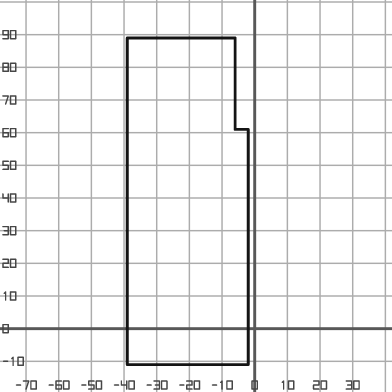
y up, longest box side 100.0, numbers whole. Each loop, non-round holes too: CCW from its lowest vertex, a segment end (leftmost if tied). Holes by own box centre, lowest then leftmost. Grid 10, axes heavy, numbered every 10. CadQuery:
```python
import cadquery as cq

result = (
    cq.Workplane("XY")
    .moveTo(-39.0, -11.0)
    .lineTo(-2.0, -11.0)
    .lineTo(-2.0, 61.0)
    .lineTo(-6.0, 61.0)
    .lineTo(-6.0, 89.0)
    .lineTo(-39.0, 89.0)
    .close()
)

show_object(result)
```